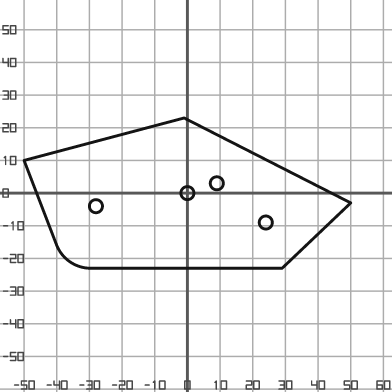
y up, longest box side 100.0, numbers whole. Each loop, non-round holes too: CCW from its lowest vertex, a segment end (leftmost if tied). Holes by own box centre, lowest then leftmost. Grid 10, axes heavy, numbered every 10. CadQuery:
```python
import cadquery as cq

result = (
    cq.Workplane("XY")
    .moveTo(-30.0, -23.0)
    .lineTo(29.0, -23.0)
    .lineTo(50.0, -3.0)
    .lineTo(-1.0, 23.0)
    .lineTo(-50.0, 10.0)
    .lineTo(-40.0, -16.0)
    .threePointArc((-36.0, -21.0), (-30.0, -23.0))
    .close()
    .moveTo(24.0, -9.0)
    .circle(2.0)
    .moveTo(-28.0, -4.0)
    .circle(2.0)
    .moveTo(0.0, 0.0)
    .circle(2.0)
    .moveTo(9.0, 3.0)
    .circle(2.0)
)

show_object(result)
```